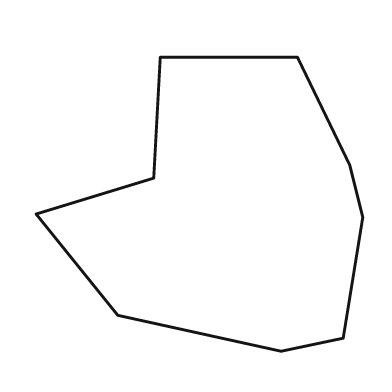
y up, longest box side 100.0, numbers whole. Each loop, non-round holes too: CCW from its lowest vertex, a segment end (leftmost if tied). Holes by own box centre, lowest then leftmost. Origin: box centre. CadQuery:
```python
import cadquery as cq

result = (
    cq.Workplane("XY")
    .moveTo(25.0, -45.0)
    .lineTo(44.0, -41.0)
    .lineTo(50.0, -4.0)
    .lineTo(46.0, 12.0)
    .lineTo(30.0, 45.0)
    .lineTo(-12.0, 45.0)
    .lineTo(-14.0, 8.0)
    .lineTo(-50.0, -3.0)
    .lineTo(-25.0, -34.0)
    .close()
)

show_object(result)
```